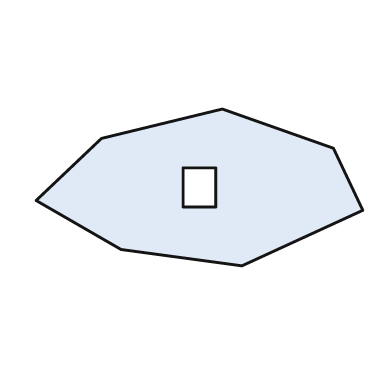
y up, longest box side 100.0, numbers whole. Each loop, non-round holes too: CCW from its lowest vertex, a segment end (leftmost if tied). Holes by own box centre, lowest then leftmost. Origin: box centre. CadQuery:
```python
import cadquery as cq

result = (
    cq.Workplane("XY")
    .moveTo(13.0, -24.0)
    .lineTo(50.0, -7.0)
    .lineTo(41.0, 12.0)
    .lineTo(7.0, 24.0)
    .lineTo(-30.0, 15.0)
    .lineTo(-50.0, -4.0)
    .lineTo(-24.0, -19.0)
    .close()
    .moveTo(-5.0, -6.0)
    .lineTo(5.0, -6.0)
    .lineTo(5.0, 6.0)
    .lineTo(-5.0, 6.0)
    .close()
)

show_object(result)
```